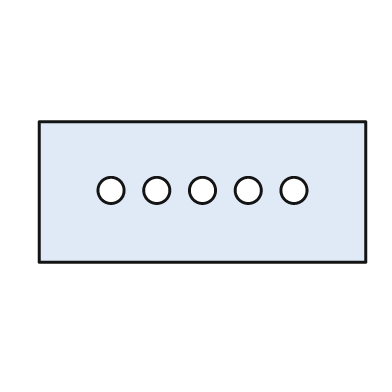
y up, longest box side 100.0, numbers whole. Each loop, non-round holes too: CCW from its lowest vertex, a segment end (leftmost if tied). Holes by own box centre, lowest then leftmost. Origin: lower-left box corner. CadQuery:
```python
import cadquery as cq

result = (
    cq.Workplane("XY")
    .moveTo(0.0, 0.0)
    .lineTo(100.0, 0.0)
    .lineTo(100.0, 43.0)
    .lineTo(0.0, 43.0)
    .close()
    .moveTo(22.0, 22.0)
    .circle(4.0)
    .moveTo(36.0, 22.0)
    .circle(4.0)
    .moveTo(50.0, 22.0)
    .circle(4.0)
    .moveTo(64.0, 22.0)
    .circle(4.0)
    .moveTo(78.0, 22.0)
    .circle(4.0)
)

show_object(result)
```